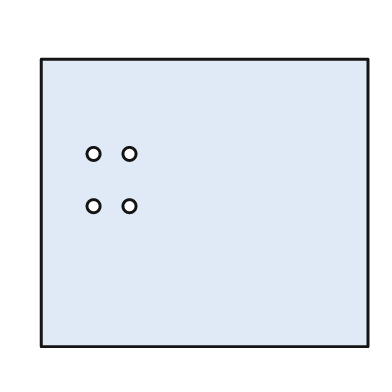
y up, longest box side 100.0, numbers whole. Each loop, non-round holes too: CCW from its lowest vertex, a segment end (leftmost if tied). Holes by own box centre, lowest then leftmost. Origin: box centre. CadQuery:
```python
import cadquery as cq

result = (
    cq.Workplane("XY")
    .moveTo(-50.0, -44.0)
    .lineTo(50.0, -44.0)
    .lineTo(50.0, 44.0)
    .lineTo(-50.0, 44.0)
    .close()
    .moveTo(-34.0, -1.0)
    .circle(2.0)
    .moveTo(-23.0, -1.0)
    .circle(2.0)
    .moveTo(-34.0, 15.0)
    .circle(2.0)
    .moveTo(-23.0, 15.0)
    .circle(2.0)
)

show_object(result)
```